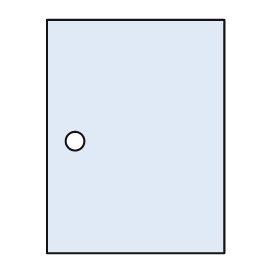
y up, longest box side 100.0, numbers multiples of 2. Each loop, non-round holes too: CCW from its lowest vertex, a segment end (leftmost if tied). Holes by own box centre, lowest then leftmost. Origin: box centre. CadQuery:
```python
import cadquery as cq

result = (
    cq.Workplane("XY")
    .moveTo(-38.0, -50.0)
    .lineTo(38.0, -50.0)
    .lineTo(38.0, 50.0)
    .lineTo(-38.0, 50.0)
    .close()
    .moveTo(-26.0, -2.0)
    .circle(4.0)
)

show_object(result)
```